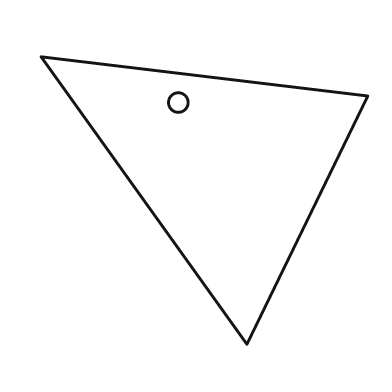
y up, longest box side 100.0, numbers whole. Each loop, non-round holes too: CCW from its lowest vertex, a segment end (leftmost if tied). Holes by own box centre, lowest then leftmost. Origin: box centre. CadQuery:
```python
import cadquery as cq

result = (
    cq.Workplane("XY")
    .moveTo(13.0, -44.0)
    .lineTo(50.0, 32.0)
    .lineTo(-50.0, 44.0)
    .close()
    .moveTo(-8.0, 30.0)
    .circle(3.0)
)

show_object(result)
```